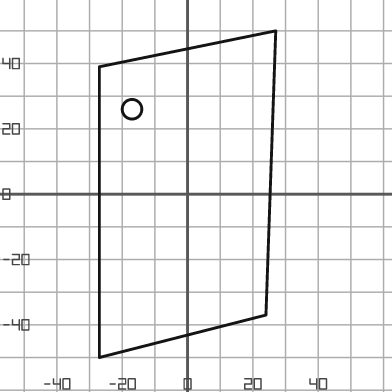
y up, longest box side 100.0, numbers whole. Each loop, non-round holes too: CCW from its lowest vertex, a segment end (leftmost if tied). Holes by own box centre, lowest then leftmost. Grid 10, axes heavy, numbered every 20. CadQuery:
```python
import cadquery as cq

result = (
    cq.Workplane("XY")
    .moveTo(-27.0, -50.0)
    .lineTo(24.0, -37.0)
    .lineTo(27.0, 50.0)
    .lineTo(-27.0, 39.0)
    .close()
    .moveTo(-17.0, 26.0)
    .circle(3.0)
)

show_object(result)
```